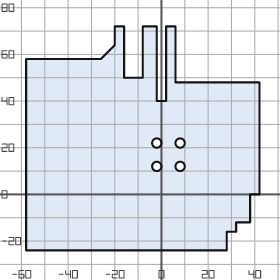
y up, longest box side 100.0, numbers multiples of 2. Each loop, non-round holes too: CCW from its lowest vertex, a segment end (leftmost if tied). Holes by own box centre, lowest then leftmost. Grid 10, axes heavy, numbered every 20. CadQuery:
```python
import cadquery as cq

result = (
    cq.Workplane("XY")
    .moveTo(-58.0, -24.0)
    .lineTo(28.0, -24.0)
    .lineTo(28.0, -16.0)
    .lineTo(32.0, -16.0)
    .lineTo(32.0, -12.0)
    .lineTo(38.0, -12.0)
    .lineTo(38.0, 0.0)
    .lineTo(42.0, 0.0)
    .lineTo(42.0, 48.0)
    .lineTo(6.0, 48.0)
    .lineTo(6.0, 72.0)
    .lineTo(2.0, 72.0)
    .lineTo(2.0, 40.0)
    .lineTo(-2.0, 40.0)
    .lineTo(-2.0, 72.0)
    .lineTo(-8.0, 72.0)
    .lineTo(-8.0, 50.0)
    .lineTo(-16.0, 50.0)
    .lineTo(-16.0, 72.0)
    .lineTo(-20.0, 72.0)
    .lineTo(-20.0, 64.0)
    .lineTo(-26.0, 58.0)
    .lineTo(-58.0, 58.0)
    .close()
    .moveTo(-2.0, 12.0)
    .circle(2.0)
    .moveTo(8.0, 12.0)
    .circle(2.0)
    .moveTo(-2.0, 22.0)
    .circle(2.0)
    .moveTo(8.0, 22.0)
    .circle(2.0)
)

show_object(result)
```